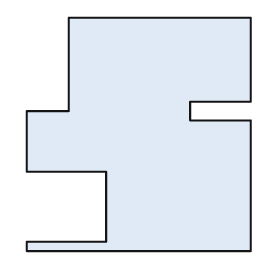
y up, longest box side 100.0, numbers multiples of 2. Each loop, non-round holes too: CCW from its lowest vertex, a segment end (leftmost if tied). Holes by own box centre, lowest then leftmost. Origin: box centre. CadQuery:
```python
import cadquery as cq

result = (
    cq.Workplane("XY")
    .moveTo(-48.0, -50.0)
    .lineTo(48.0, -50.0)
    .lineTo(48.0, 6.0)
    .lineTo(22.0, 6.0)
    .lineTo(22.0, 14.0)
    .lineTo(48.0, 14.0)
    .lineTo(48.0, 50.0)
    .lineTo(-30.0, 50.0)
    .lineTo(-30.0, 10.0)
    .lineTo(-48.0, 10.0)
    .lineTo(-48.0, -16.0)
    .lineTo(-14.0, -16.0)
    .lineTo(-14.0, -46.0)
    .lineTo(-48.0, -46.0)
    .close()
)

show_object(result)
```